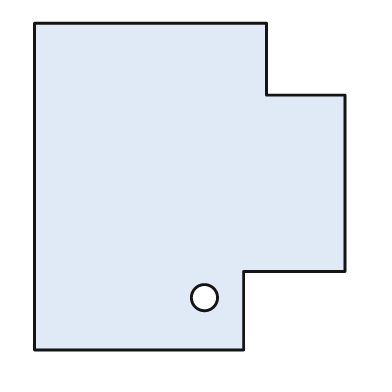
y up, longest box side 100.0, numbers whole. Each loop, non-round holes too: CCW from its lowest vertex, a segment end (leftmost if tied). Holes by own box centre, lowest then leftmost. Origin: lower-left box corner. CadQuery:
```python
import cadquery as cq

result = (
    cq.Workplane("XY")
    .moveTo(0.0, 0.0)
    .lineTo(64.0, 0.0)
    .lineTo(64.0, 24.0)
    .lineTo(95.0, 24.0)
    .lineTo(95.0, 78.0)
    .lineTo(71.0, 78.0)
    .lineTo(71.0, 100.0)
    .lineTo(0.0, 100.0)
    .close()
    .moveTo(52.0, 16.0)
    .circle(4.0)
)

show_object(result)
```